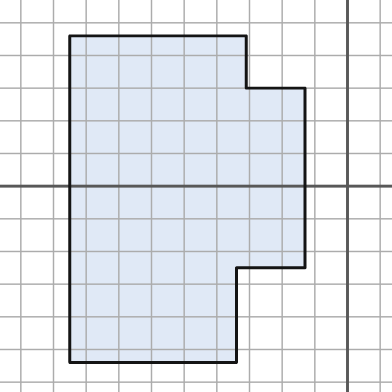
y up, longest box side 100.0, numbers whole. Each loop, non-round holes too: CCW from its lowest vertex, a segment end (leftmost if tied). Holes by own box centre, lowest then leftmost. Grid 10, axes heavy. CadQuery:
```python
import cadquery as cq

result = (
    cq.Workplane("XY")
    .moveTo(-85.0, -54.0)
    .lineTo(-34.0, -54.0)
    .lineTo(-34.0, -25.0)
    .lineTo(-13.0, -25.0)
    .lineTo(-13.0, 30.0)
    .lineTo(-31.0, 30.0)
    .lineTo(-31.0, 46.0)
    .lineTo(-85.0, 46.0)
    .close()
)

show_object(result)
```